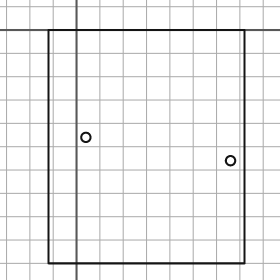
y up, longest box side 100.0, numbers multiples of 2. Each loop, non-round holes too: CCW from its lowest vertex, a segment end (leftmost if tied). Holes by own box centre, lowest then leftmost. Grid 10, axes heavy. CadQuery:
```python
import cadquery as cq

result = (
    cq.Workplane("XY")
    .moveTo(-12.0, -100.0)
    .lineTo(72.0, -100.0)
    .lineTo(72.0, 0.0)
    .lineTo(-12.0, 0.0)
    .close()
    .moveTo(66.0, -56.0)
    .circle(2.0)
    .moveTo(4.0, -46.0)
    .circle(2.0)
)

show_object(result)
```